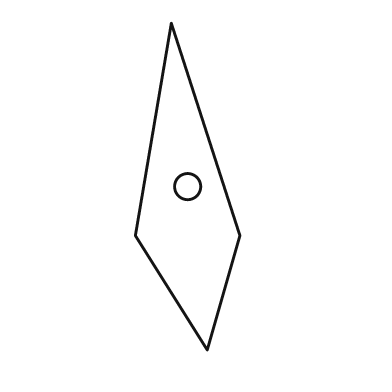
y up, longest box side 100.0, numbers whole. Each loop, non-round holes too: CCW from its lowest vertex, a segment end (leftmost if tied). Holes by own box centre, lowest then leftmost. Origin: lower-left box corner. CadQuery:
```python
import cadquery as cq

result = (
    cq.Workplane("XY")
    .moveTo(22.0, 0.0)
    .lineTo(32.0, 35.0)
    .lineTo(11.0, 100.0)
    .lineTo(0.0, 35.0)
    .close()
    .moveTo(16.0, 50.0)
    .circle(4.0)
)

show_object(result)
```